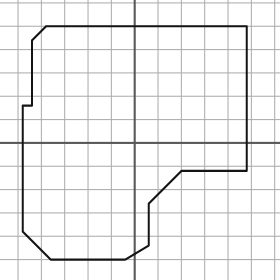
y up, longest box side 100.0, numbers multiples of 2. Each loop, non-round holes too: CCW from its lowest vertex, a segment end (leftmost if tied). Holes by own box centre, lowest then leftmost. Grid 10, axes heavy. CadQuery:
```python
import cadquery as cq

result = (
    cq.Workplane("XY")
    .moveTo(-36.0, -50.0)
    .lineTo(-4.0, -50.0)
    .lineTo(6.0, -44.0)
    .lineTo(6.0, -26.0)
    .lineTo(20.0, -12.0)
    .lineTo(48.0, -12.0)
    .lineTo(48.0, 50.0)
    .lineTo(-38.0, 50.0)
    .lineTo(-44.0, 44.0)
    .lineTo(-44.0, 16.0)
    .lineTo(-48.0, 16.0)
    .lineTo(-48.0, -38.0)
    .close()
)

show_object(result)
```